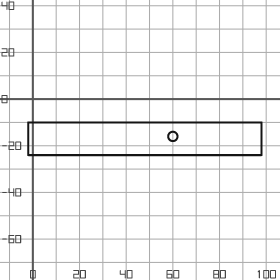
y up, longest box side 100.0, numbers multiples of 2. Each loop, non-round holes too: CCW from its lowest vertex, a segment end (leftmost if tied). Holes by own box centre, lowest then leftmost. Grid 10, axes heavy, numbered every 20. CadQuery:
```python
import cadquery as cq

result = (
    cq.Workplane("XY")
    .moveTo(-2.0, -24.0)
    .lineTo(98.0, -24.0)
    .lineTo(98.0, -10.0)
    .lineTo(-2.0, -10.0)
    .close()
    .moveTo(60.0, -16.0)
    .circle(2.0)
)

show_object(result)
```